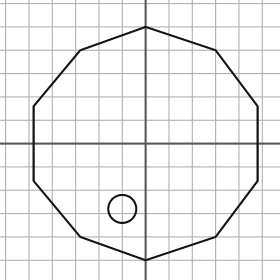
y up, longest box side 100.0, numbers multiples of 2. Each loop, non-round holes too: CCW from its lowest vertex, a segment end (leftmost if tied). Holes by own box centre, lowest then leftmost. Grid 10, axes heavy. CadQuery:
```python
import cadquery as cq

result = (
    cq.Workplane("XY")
    .moveTo(0.0, -50.0)
    .lineTo(30.0, -40.0)
    .lineTo(48.0, -16.0)
    .lineTo(48.0, 16.0)
    .lineTo(30.0, 40.0)
    .lineTo(0.0, 50.0)
    .lineTo(-28.0, 40.0)
    .lineTo(-48.0, 16.0)
    .lineTo(-48.0, -16.0)
    .lineTo(-28.0, -40.0)
    .close()
    .moveTo(-10.0, -28.0)
    .circle(6.0)
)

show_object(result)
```